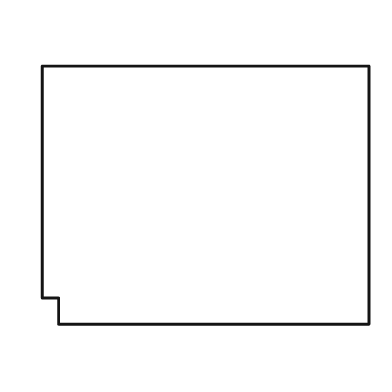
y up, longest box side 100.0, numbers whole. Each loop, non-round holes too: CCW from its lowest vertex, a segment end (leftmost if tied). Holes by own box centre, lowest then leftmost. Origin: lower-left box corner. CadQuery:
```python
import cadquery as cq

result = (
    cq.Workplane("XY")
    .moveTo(5.0, 0.0)
    .lineTo(100.0, 0.0)
    .lineTo(100.0, 79.0)
    .lineTo(0.0, 79.0)
    .lineTo(0.0, 8.0)
    .lineTo(5.0, 8.0)
    .close()
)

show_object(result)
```